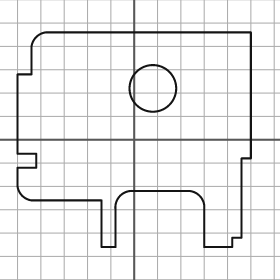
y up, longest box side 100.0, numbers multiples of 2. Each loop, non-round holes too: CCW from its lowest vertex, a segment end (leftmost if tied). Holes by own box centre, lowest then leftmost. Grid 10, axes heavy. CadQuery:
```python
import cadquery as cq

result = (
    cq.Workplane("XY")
    .moveTo(-14.0, -46.0)
    .lineTo(-8.0, -46.0)
    .lineTo(-8.0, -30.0)
    .threePointArc((-6.0, -24.0), (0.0, -22.0))
    .lineTo(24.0, -22.0)
    .threePointArc((28.0, -24.0), (30.0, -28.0))
    .lineTo(30.0, -46.0)
    .lineTo(42.0, -46.0)
    .lineTo(42.0, -42.0)
    .lineTo(46.0, -42.0)
    .lineTo(46.0, -8.0)
    .lineTo(50.0, -8.0)
    .lineTo(50.0, 46.0)
    .lineTo(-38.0, 46.0)
    .threePointArc((-42.0, 44.0), (-44.0, 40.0))
    .lineTo(-44.0, 28.0)
    .lineTo(-50.0, 28.0)
    .lineTo(-50.0, -6.0)
    .lineTo(-42.0, -6.0)
    .lineTo(-42.0, -12.0)
    .lineTo(-50.0, -12.0)
    .lineTo(-50.0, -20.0)
    .threePointArc((-48.0, -24.0), (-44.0, -26.0))
    .lineTo(-14.0, -26.0)
    .close()
    .moveTo(8.0, 22.0)
    .circle(10.0)
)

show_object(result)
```